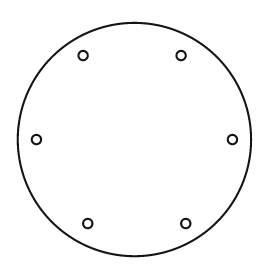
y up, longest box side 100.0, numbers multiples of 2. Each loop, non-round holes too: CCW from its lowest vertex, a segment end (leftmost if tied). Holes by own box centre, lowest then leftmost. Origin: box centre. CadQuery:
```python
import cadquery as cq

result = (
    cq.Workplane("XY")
    .moveTo(0.0, 0.0)
    .circle(50.0)
    .moveTo(-20.0, -36.0)
    .circle(2.0)
    .moveTo(22.0, -36.0)
    .circle(2.0)
    .moveTo(-42.0, 0.0)
    .circle(2.0)
    .moveTo(42.0, 0.0)
    .circle(2.0)
    .moveTo(-22.0, 36.0)
    .circle(2.0)
    .moveTo(20.0, 36.0)
    .circle(2.0)
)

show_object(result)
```